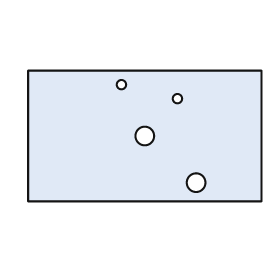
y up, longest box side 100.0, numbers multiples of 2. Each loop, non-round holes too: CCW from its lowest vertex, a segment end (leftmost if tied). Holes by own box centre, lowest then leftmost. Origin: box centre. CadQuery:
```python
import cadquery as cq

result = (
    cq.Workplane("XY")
    .moveTo(-50.0, -28.0)
    .lineTo(50.0, -28.0)
    .lineTo(50.0, 28.0)
    .lineTo(-50.0, 28.0)
    .close()
    .moveTo(22.0, -20.0)
    .circle(4.0)
    .moveTo(0.0, 0.0)
    .circle(4.0)
    .moveTo(14.0, 16.0)
    .circle(2.0)
    .moveTo(-10.0, 22.0)
    .circle(2.0)
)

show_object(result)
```